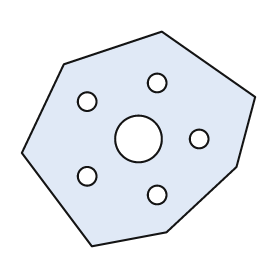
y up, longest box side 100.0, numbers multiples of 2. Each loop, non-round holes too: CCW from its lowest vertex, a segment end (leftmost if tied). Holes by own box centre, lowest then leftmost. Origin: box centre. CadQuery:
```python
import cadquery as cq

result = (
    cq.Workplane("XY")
    .moveTo(-20.0, -46.0)
    .lineTo(12.0, -40.0)
    .lineTo(42.0, -12.0)
    .lineTo(50.0, 18.0)
    .lineTo(10.0, 46.0)
    .lineTo(-32.0, 32.0)
    .lineTo(-50.0, -6.0)
    .close()
    .moveTo(8.0, -24.0)
    .circle(4.0)
    .moveTo(-22.0, -16.0)
    .circle(4.0)
    .moveTo(0.0, 0.0)
    .circle(10.0)
    .moveTo(26.0, 0.0)
    .circle(4.0)
    .moveTo(-22.0, 16.0)
    .circle(4.0)
    .moveTo(8.0, 24.0)
    .circle(4.0)
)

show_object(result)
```